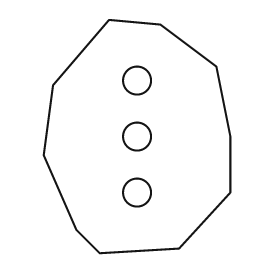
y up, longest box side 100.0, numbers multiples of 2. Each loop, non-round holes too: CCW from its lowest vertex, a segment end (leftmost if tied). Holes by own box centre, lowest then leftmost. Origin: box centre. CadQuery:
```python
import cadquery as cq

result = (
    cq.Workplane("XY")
    .moveTo(-16.0, -50.0)
    .lineTo(18.0, -48.0)
    .lineTo(40.0, -24.0)
    .lineTo(40.0, 0.0)
    .lineTo(34.0, 30.0)
    .lineTo(10.0, 48.0)
    .lineTo(-12.0, 50.0)
    .lineTo(-36.0, 22.0)
    .lineTo(-40.0, -8.0)
    .lineTo(-26.0, -40.0)
    .close()
    .moveTo(0.0, -24.0)
    .circle(6.0)
    .moveTo(0.0, 0.0)
    .circle(6.0)
    .moveTo(0.0, 24.0)
    .circle(6.0)
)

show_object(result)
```